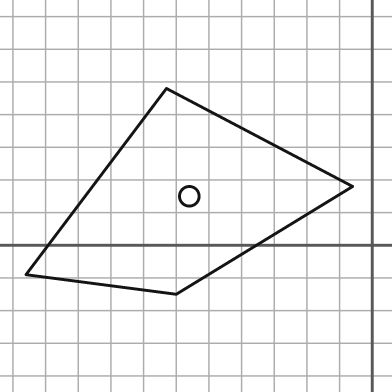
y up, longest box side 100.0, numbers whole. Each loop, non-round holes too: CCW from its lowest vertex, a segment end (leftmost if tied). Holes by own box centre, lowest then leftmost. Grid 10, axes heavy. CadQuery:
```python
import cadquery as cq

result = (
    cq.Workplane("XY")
    .moveTo(-60.0, -15.0)
    .lineTo(-6.0, 18.0)
    .lineTo(-63.0, 48.0)
    .lineTo(-106.0, -9.0)
    .close()
    .moveTo(-56.0, 15.0)
    .circle(3.0)
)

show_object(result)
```